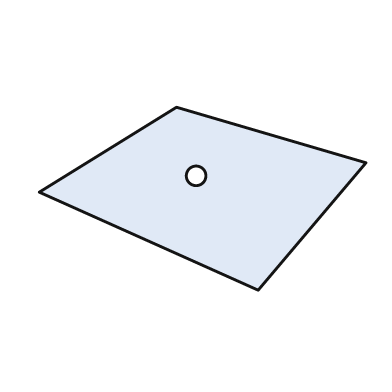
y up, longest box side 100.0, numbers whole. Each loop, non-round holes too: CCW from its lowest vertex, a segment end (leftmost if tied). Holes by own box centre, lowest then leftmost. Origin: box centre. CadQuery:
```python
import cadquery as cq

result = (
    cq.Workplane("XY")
    .moveTo(17.0, -28.0)
    .lineTo(50.0, 11.0)
    .lineTo(-8.0, 28.0)
    .lineTo(-50.0, 2.0)
    .close()
    .moveTo(-2.0, 7.0)
    .circle(3.0)
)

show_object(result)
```